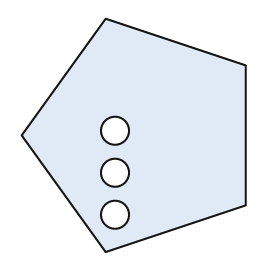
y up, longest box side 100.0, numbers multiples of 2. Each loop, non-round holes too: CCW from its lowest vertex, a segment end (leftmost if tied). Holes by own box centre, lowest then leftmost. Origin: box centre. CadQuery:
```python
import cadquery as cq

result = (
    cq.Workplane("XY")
    .moveTo(-12.0, -50.0)
    .lineTo(48.0, -30.0)
    .lineTo(48.0, 30.0)
    .lineTo(-12.0, 50.0)
    .lineTo(-48.0, 0.0)
    .close()
    .moveTo(-8.0, -34.0)
    .circle(6.0)
    .moveTo(-8.0, -16.0)
    .circle(6.0)
    .moveTo(-8.0, 2.0)
    .circle(6.0)
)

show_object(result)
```